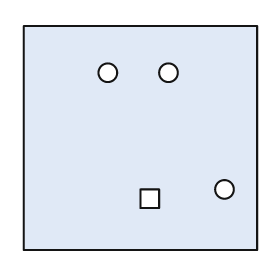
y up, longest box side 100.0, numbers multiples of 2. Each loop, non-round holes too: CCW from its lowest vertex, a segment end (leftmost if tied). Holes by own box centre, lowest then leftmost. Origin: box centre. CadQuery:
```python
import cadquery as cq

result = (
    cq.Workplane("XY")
    .moveTo(-50.0, -48.0)
    .lineTo(50.0, -48.0)
    .lineTo(50.0, 48.0)
    .lineTo(-50.0, 48.0)
    .close()
    .moveTo(0.0, -30.0)
    .lineTo(8.0, -30.0)
    .lineTo(8.0, -22.0)
    .lineTo(0.0, -22.0)
    .close()
    .moveTo(36.0, -22.0)
    .circle(4.0)
    .moveTo(-14.0, 28.0)
    .circle(4.0)
    .moveTo(12.0, 28.0)
    .circle(4.0)
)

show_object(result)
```